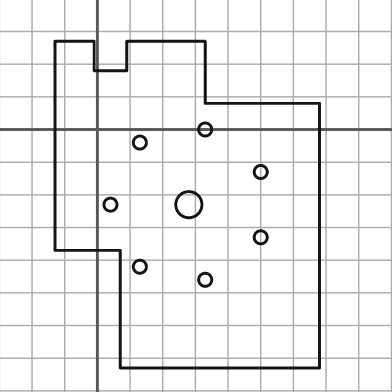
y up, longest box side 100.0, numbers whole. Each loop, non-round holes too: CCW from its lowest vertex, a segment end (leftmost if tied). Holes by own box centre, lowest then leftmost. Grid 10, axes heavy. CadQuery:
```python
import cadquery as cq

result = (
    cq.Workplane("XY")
    .moveTo(7.0, -73.0)
    .lineTo(68.0, -73.0)
    .lineTo(68.0, 8.0)
    .lineTo(33.0, 8.0)
    .lineTo(33.0, 27.0)
    .lineTo(9.0, 27.0)
    .lineTo(9.0, 18.0)
    .lineTo(-1.0, 18.0)
    .lineTo(-1.0, 27.0)
    .lineTo(-13.0, 27.0)
    .lineTo(-13.0, -37.0)
    .lineTo(7.0, -37.0)
    .close()
    .moveTo(33.0, -46.0)
    .circle(2.0)
    .moveTo(13.0, -42.0)
    .circle(2.0)
    .moveTo(50.0, -33.0)
    .circle(2.0)
    .moveTo(4.0, -23.0)
    .circle(2.0)
    .moveTo(28.0, -23.0)
    .circle(4.0)
    .moveTo(50.0, -13.0)
    .circle(2.0)
    .moveTo(13.0, -4.0)
    .circle(2.0)
    .moveTo(33.0, 0.0)
    .circle(2.0)
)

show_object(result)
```